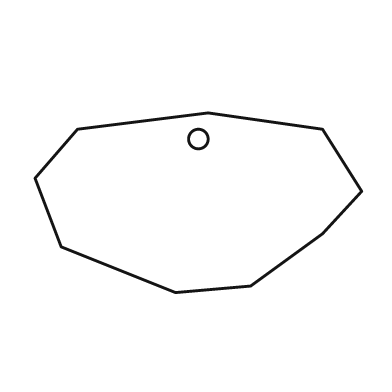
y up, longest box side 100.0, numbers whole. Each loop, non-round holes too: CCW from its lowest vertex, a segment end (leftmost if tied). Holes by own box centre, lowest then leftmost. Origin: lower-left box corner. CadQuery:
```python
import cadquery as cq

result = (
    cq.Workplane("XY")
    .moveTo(43.0, 0.0)
    .lineTo(66.0, 2.0)
    .lineTo(88.0, 18.0)
    .lineTo(100.0, 31.0)
    .lineTo(88.0, 50.0)
    .lineTo(53.0, 55.0)
    .lineTo(13.0, 50.0)
    .lineTo(0.0, 35.0)
    .lineTo(8.0, 14.0)
    .close()
    .moveTo(50.0, 47.0)
    .circle(3.0)
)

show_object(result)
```